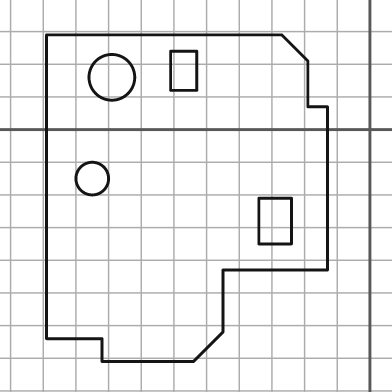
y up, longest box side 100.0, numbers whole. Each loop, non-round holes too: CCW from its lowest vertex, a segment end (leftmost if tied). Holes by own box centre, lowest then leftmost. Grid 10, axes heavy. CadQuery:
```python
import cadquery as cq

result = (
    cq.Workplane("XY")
    .moveTo(-82.0, -71.0)
    .lineTo(-54.0, -71.0)
    .lineTo(-45.0, -62.0)
    .lineTo(-45.0, -43.0)
    .lineTo(-13.0, -43.0)
    .lineTo(-13.0, 7.0)
    .lineTo(-19.0, 7.0)
    .lineTo(-19.0, 21.0)
    .lineTo(-27.0, 29.0)
    .lineTo(-99.0, 29.0)
    .lineTo(-99.0, -64.0)
    .lineTo(-82.0, -64.0)
    .close()
    .moveTo(-34.0, -35.0)
    .lineTo(-24.0, -35.0)
    .lineTo(-24.0, -21.0)
    .lineTo(-34.0, -21.0)
    .close()
    .moveTo(-85.0, -15.0)
    .circle(5.0)
    .moveTo(-79.0, 16.0)
    .circle(7.0)
    .moveTo(-61.0, 12.0)
    .lineTo(-53.0, 12.0)
    .lineTo(-53.0, 24.0)
    .lineTo(-61.0, 24.0)
    .close()
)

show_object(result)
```